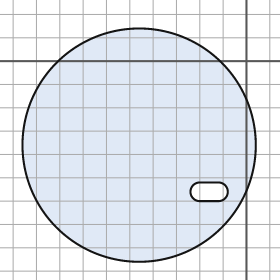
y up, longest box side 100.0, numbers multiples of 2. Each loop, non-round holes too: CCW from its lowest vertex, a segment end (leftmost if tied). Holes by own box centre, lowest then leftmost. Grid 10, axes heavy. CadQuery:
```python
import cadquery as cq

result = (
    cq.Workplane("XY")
    .moveTo(-46.0, -36.0)
    .circle(50.0)
    .moveTo(-20.0, -60.0)
    .lineTo(-12.0, -60.0)
    .threePointArc((-8.0, -56.0), (-12.0, -52.0))
    .lineTo(-20.0, -52.0)
    .threePointArc((-24.0, -56.0), (-20.0, -60.0))
    .close()
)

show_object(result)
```